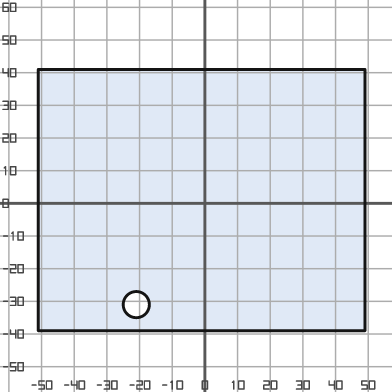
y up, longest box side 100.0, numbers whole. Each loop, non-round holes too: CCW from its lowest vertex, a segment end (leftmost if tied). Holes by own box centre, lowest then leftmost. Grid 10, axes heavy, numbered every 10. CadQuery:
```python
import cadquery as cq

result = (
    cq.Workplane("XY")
    .moveTo(-51.0, -39.0)
    .lineTo(49.0, -39.0)
    .lineTo(49.0, 41.0)
    .lineTo(-51.0, 41.0)
    .close()
    .moveTo(-21.0, -31.0)
    .circle(4.0)
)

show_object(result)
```